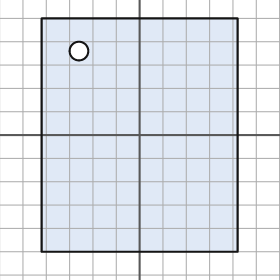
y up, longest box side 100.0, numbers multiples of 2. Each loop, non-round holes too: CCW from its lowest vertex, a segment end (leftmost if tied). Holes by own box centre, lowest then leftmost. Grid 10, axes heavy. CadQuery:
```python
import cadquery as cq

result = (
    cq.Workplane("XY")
    .moveTo(-42.0, -50.0)
    .lineTo(42.0, -50.0)
    .lineTo(42.0, 50.0)
    .lineTo(-42.0, 50.0)
    .close()
    .moveTo(-26.0, 36.0)
    .circle(4.0)
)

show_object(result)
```